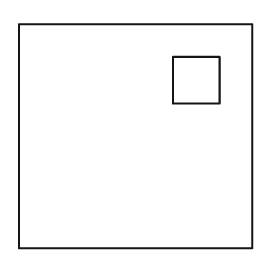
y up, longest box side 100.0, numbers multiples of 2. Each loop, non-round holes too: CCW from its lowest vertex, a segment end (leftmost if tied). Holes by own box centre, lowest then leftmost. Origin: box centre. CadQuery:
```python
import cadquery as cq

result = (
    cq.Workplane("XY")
    .moveTo(-50.0, -48.0)
    .lineTo(50.0, -48.0)
    .lineTo(50.0, 48.0)
    .lineTo(-50.0, 48.0)
    .close()
    .moveTo(16.0, 14.0)
    .lineTo(36.0, 14.0)
    .lineTo(36.0, 34.0)
    .lineTo(16.0, 34.0)
    .close()
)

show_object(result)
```